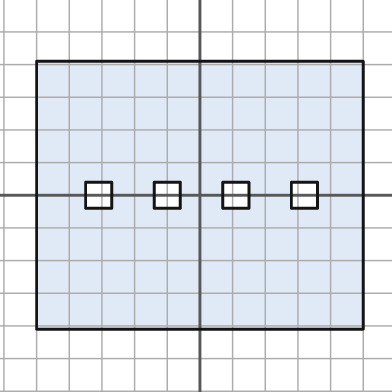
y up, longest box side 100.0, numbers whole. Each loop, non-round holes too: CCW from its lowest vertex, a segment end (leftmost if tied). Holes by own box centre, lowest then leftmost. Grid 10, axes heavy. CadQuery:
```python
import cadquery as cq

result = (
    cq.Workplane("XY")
    .moveTo(-50.0, -41.0)
    .lineTo(50.0, -41.0)
    .lineTo(50.0, 41.0)
    .lineTo(-50.0, 41.0)
    .close()
    .moveTo(-35.0, -4.0)
    .lineTo(-27.0, -4.0)
    .lineTo(-27.0, 4.0)
    .lineTo(-35.0, 4.0)
    .close()
    .moveTo(-14.0, -4.0)
    .lineTo(-6.0, -4.0)
    .lineTo(-6.0, 4.0)
    .lineTo(-14.0, 4.0)
    .close()
    .moveTo(7.0, -4.0)
    .lineTo(15.0, -4.0)
    .lineTo(15.0, 4.0)
    .lineTo(7.0, 4.0)
    .close()
    .moveTo(28.0, -4.0)
    .lineTo(36.0, -4.0)
    .lineTo(36.0, 4.0)
    .lineTo(28.0, 4.0)
    .close()
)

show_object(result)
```